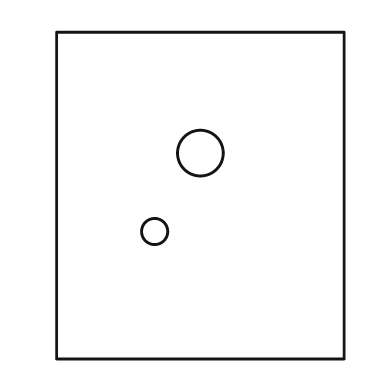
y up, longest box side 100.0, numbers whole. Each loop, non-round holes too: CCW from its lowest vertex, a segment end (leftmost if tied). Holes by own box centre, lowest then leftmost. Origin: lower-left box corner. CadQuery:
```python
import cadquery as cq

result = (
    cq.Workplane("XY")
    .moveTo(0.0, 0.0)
    .lineTo(88.0, 0.0)
    .lineTo(88.0, 100.0)
    .lineTo(0.0, 100.0)
    .close()
    .moveTo(30.0, 39.0)
    .circle(4.0)
    .moveTo(44.0, 63.0)
    .circle(7.0)
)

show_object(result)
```